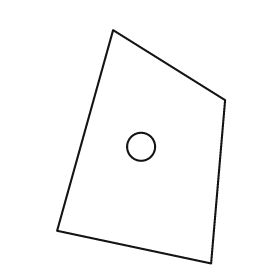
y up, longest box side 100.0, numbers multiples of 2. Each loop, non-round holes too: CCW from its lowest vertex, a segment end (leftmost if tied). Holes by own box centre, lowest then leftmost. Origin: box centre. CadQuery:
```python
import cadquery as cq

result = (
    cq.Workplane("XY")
    .moveTo(30.0, -50.0)
    .lineTo(36.0, 20.0)
    .lineTo(-12.0, 50.0)
    .lineTo(-36.0, -36.0)
    .close()
    .moveTo(0.0, 0.0)
    .circle(6.0)
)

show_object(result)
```